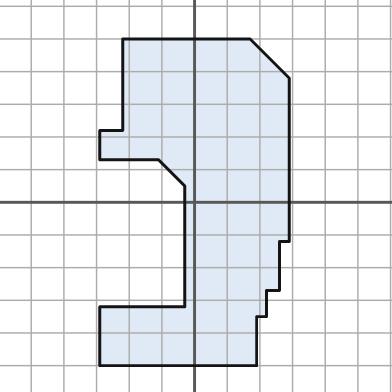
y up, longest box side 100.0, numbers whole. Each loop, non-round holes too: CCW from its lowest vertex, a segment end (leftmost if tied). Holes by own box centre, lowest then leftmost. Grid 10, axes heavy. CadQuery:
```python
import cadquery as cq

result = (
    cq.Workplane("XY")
    .moveTo(-29.0, -50.0)
    .lineTo(19.0, -50.0)
    .lineTo(19.0, -35.0)
    .lineTo(22.0, -35.0)
    .lineTo(22.0, -27.0)
    .lineTo(26.0, -27.0)
    .lineTo(26.0, -12.0)
    .lineTo(29.0, -12.0)
    .lineTo(29.0, 38.0)
    .lineTo(17.0, 50.0)
    .lineTo(-22.0, 50.0)
    .lineTo(-22.0, 22.0)
    .lineTo(-29.0, 22.0)
    .lineTo(-29.0, 13.0)
    .lineTo(-11.0, 13.0)
    .lineTo(-3.0, 5.0)
    .lineTo(-3.0, -32.0)
    .lineTo(-29.0, -32.0)
    .close()
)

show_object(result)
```